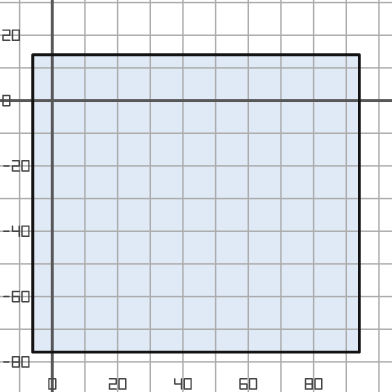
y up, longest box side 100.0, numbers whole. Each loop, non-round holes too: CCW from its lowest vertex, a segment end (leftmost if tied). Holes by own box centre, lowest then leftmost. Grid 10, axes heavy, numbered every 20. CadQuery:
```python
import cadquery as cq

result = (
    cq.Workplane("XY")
    .moveTo(-6.0, -77.0)
    .lineTo(94.0, -77.0)
    .lineTo(94.0, 14.0)
    .lineTo(-6.0, 14.0)
    .close()
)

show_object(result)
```